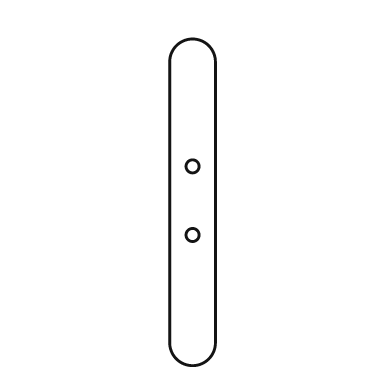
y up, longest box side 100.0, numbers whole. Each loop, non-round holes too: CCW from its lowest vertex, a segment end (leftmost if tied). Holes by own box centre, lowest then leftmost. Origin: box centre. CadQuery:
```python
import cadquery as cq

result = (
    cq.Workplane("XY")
    .moveTo(-7.0, -43.0)
    .threePointArc((0.0, -50.0), (7.0, -43.0))
    .lineTo(7.0, 43.0)
    .threePointArc((0.0, 50.0), (-7.0, 43.0))
    .close()
    .moveTo(0.0, -10.0)
    .circle(2.0)
    .moveTo(0.0, 11.0)
    .circle(2.0)
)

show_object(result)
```